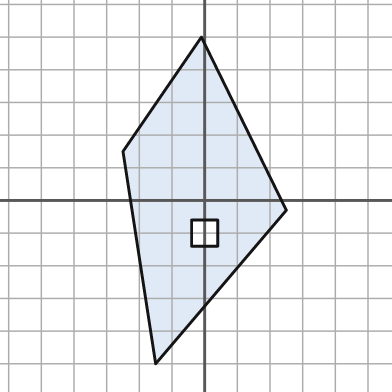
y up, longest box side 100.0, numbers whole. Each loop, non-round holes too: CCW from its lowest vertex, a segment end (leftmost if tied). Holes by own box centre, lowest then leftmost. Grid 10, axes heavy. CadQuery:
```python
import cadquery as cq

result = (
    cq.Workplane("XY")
    .moveTo(-15.0, -50.0)
    .lineTo(25.0, -3.0)
    .lineTo(-1.0, 50.0)
    .lineTo(-25.0, 15.0)
    .close()
    .moveTo(-4.0, -14.0)
    .lineTo(4.0, -14.0)
    .lineTo(4.0, -6.0)
    .lineTo(-4.0, -6.0)
    .close()
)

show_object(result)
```